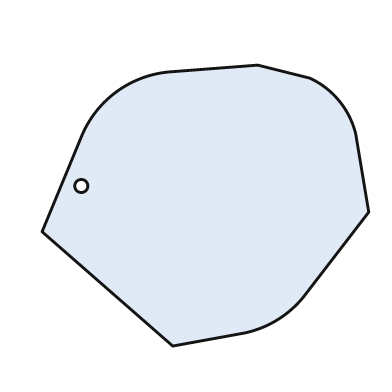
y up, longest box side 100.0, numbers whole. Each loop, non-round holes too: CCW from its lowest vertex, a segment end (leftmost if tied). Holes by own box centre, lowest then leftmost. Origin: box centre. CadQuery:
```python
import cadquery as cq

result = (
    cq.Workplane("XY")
    .moveTo(-10.0, -43.0)
    .lineTo(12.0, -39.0)
    .threePointArc((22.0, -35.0), (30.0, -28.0))
    .lineTo(50.0, -2.0)
    .lineTo(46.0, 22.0)
    .threePointArc((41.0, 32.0), (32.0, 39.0))
    .lineTo(16.0, 43.0)
    .lineTo(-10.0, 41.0)
    .threePointArc((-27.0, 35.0), (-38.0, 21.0))
    .lineTo(-50.0, -8.0)
    .close()
    .moveTo(-38.0, 6.0)
    .circle(2.0)
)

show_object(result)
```